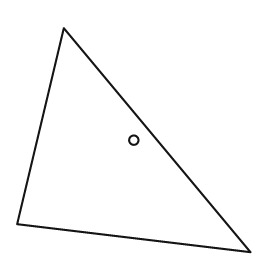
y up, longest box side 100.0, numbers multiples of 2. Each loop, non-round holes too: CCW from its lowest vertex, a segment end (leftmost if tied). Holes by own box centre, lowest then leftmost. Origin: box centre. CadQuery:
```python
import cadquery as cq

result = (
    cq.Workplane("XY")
    .moveTo(50.0, -48.0)
    .lineTo(-30.0, 48.0)
    .lineTo(-50.0, -36.0)
    .close()
    .moveTo(0.0, 0.0)
    .circle(2.0)
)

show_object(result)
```